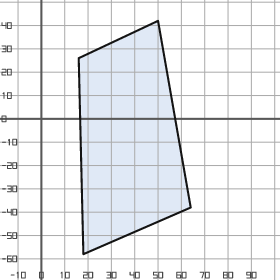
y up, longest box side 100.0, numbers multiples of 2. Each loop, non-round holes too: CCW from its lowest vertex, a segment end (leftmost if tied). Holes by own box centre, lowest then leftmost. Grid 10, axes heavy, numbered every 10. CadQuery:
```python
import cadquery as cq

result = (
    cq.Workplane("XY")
    .moveTo(18.0, -58.0)
    .lineTo(64.0, -38.0)
    .lineTo(50.0, 42.0)
    .lineTo(16.0, 26.0)
    .close()
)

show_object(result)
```